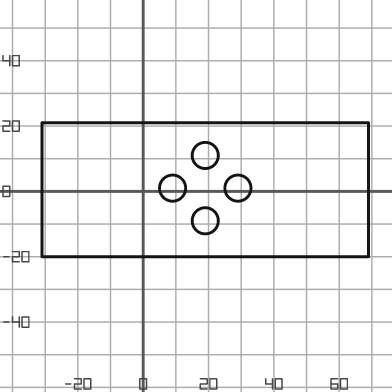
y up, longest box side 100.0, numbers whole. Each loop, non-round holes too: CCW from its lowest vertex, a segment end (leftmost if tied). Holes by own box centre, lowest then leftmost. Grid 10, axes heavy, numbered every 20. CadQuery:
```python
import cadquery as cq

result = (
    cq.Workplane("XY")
    .moveTo(-31.0, -20.0)
    .lineTo(69.0, -20.0)
    .lineTo(69.0, 21.0)
    .lineTo(-31.0, 21.0)
    .close()
    .moveTo(19.0, -9.0)
    .circle(4.0)
    .moveTo(9.0, 1.0)
    .circle(4.0)
    .moveTo(29.0, 1.0)
    .circle(4.0)
    .moveTo(19.0, 11.0)
    .circle(4.0)
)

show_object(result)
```